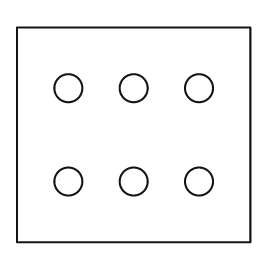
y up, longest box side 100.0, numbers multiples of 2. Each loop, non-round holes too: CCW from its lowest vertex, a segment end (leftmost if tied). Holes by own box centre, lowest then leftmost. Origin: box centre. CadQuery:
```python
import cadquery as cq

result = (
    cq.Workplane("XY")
    .moveTo(-50.0, -46.0)
    .lineTo(50.0, -46.0)
    .lineTo(50.0, 46.0)
    .lineTo(-50.0, 46.0)
    .close()
    .moveTo(-28.0, -20.0)
    .circle(6.0)
    .moveTo(0.0, -20.0)
    .circle(6.0)
    .moveTo(28.0, -20.0)
    .circle(6.0)
    .moveTo(-28.0, 20.0)
    .circle(6.0)
    .moveTo(0.0, 20.0)
    .circle(6.0)
    .moveTo(28.0, 20.0)
    .circle(6.0)
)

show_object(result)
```